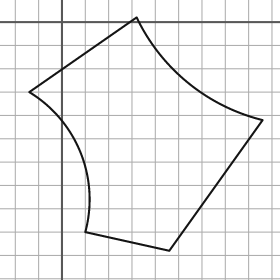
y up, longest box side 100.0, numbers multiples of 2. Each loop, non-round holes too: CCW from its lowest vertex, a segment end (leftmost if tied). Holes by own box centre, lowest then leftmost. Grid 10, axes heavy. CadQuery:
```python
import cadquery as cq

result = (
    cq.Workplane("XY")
    .moveTo(46.0, -98.0)
    .lineTo(86.0, -42.0)
    .threePointArc((54.0, -26.0), (32.0, 2.0))
    .lineTo(-14.0, -30.0)
    .threePointArc((8.0, -56.0), (10.0, -90.0))
    .close()
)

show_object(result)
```